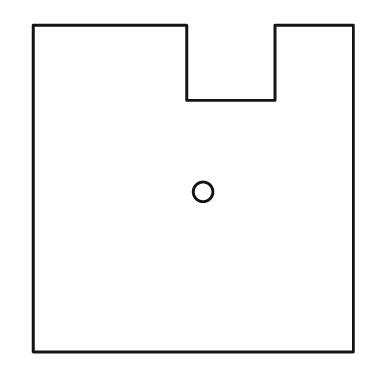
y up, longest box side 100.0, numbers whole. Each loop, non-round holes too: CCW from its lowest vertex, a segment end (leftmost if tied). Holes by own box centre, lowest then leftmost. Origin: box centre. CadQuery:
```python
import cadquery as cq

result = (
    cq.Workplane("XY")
    .moveTo(-49.0, -50.0)
    .lineTo(49.0, -50.0)
    .lineTo(49.0, 50.0)
    .lineTo(25.0, 50.0)
    .lineTo(25.0, 27.0)
    .lineTo(-2.0, 27.0)
    .lineTo(-2.0, 50.0)
    .lineTo(-49.0, 50.0)
    .close()
    .moveTo(3.0, -1.0)
    .circle(3.0)
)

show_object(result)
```